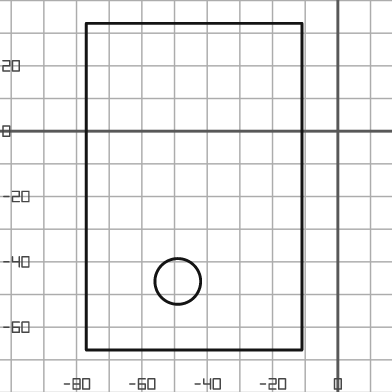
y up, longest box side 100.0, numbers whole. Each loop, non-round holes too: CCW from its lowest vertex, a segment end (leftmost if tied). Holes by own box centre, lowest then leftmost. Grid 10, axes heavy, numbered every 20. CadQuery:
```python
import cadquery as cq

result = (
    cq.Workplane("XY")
    .moveTo(-77.0, -67.0)
    .lineTo(-11.0, -67.0)
    .lineTo(-11.0, 33.0)
    .lineTo(-77.0, 33.0)
    .close()
    .moveTo(-49.0, -46.0)
    .circle(7.0)
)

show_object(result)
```